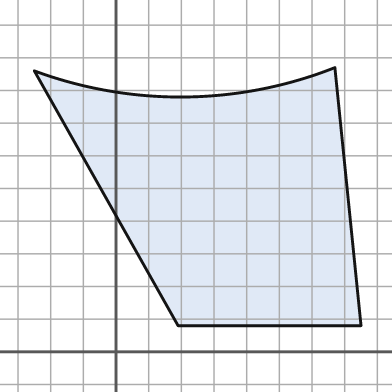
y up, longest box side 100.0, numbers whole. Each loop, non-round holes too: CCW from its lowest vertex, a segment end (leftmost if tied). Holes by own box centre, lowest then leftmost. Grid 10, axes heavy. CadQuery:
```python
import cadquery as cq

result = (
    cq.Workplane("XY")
    .moveTo(19.0, 8.0)
    .lineTo(75.0, 8.0)
    .lineTo(67.0, 87.0)
    .threePointArc((21.0, 78.0), (-25.0, 86.0))
    .close()
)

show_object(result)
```